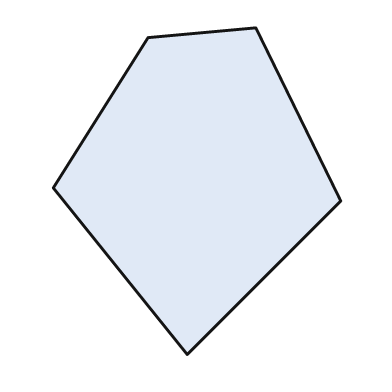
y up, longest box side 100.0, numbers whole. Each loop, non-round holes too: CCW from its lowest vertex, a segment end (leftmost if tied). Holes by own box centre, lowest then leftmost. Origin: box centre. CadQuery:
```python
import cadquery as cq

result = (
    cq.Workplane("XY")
    .moveTo(-3.0, -50.0)
    .lineTo(44.0, -3.0)
    .lineTo(18.0, 50.0)
    .lineTo(-15.0, 47.0)
    .lineTo(-44.0, 1.0)
    .close()
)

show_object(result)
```